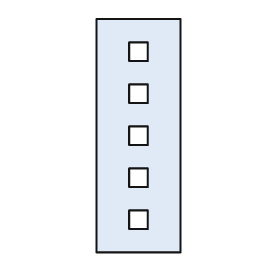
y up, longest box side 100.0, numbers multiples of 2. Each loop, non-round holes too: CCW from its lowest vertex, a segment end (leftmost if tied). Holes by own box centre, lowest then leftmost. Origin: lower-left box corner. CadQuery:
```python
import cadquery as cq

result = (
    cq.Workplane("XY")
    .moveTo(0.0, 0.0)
    .lineTo(36.0, 0.0)
    .lineTo(36.0, 100.0)
    .lineTo(0.0, 100.0)
    .close()
    .moveTo(14.0, 10.0)
    .lineTo(22.0, 10.0)
    .lineTo(22.0, 18.0)
    .lineTo(14.0, 18.0)
    .close()
    .moveTo(14.0, 28.0)
    .lineTo(22.0, 28.0)
    .lineTo(22.0, 36.0)
    .lineTo(14.0, 36.0)
    .close()
    .moveTo(14.0, 46.0)
    .lineTo(22.0, 46.0)
    .lineTo(22.0, 54.0)
    .lineTo(14.0, 54.0)
    .close()
    .moveTo(14.0, 64.0)
    .lineTo(22.0, 64.0)
    .lineTo(22.0, 72.0)
    .lineTo(14.0, 72.0)
    .close()
    .moveTo(14.0, 82.0)
    .lineTo(22.0, 82.0)
    .lineTo(22.0, 90.0)
    .lineTo(14.0, 90.0)
    .close()
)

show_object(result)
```